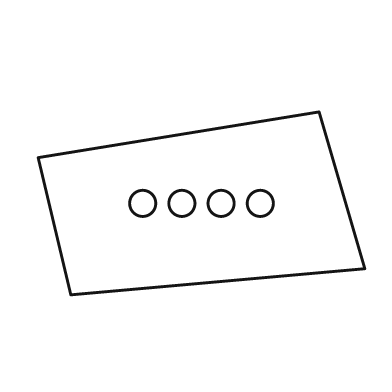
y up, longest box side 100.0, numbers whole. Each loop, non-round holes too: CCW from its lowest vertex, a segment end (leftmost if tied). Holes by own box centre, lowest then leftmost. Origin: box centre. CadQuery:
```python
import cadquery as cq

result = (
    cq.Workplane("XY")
    .moveTo(-40.0, -28.0)
    .lineTo(50.0, -20.0)
    .lineTo(36.0, 28.0)
    .lineTo(-50.0, 14.0)
    .close()
    .moveTo(-18.0, 0.0)
    .circle(4.0)
    .moveTo(-6.0, 0.0)
    .circle(4.0)
    .moveTo(6.0, 0.0)
    .circle(4.0)
    .moveTo(18.0, 0.0)
    .circle(4.0)
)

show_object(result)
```